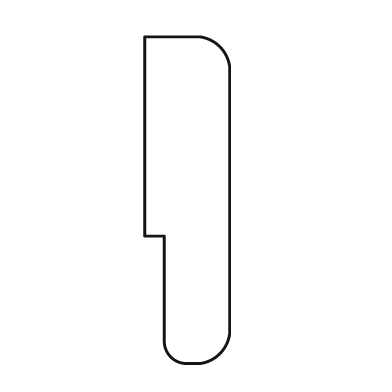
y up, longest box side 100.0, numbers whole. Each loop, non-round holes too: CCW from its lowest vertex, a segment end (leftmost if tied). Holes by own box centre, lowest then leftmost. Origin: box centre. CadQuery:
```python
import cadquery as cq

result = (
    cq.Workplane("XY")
    .moveTo(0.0, -50.0)
    .lineTo(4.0, -50.0)
    .threePointArc((10.0, -47.0), (13.0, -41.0))
    .lineTo(13.0, 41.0)
    .threePointArc((10.0, 47.0), (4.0, 50.0))
    .lineTo(-13.0, 50.0)
    .lineTo(-13.0, -11.0)
    .lineTo(-7.0, -11.0)
    .lineTo(-7.0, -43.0)
    .threePointArc((-5.0, -48.0), (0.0, -50.0))
    .close()
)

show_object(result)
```